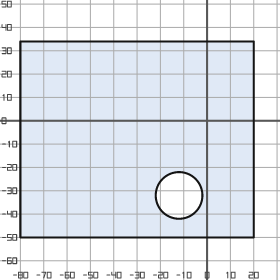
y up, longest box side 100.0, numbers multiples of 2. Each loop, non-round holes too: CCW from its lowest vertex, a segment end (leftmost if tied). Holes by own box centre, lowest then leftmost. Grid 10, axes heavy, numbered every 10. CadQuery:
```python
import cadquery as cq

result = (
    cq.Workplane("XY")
    .moveTo(-80.0, -50.0)
    .lineTo(20.0, -50.0)
    .lineTo(20.0, 34.0)
    .lineTo(-80.0, 34.0)
    .close()
    .moveTo(-12.0, -32.0)
    .circle(10.0)
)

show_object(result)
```